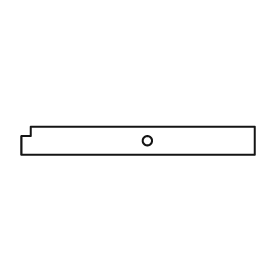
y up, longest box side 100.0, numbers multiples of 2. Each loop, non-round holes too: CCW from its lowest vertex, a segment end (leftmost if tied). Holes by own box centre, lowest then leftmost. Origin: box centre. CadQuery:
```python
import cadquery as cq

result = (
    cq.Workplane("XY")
    .moveTo(-50.0, -6.0)
    .lineTo(50.0, -6.0)
    .lineTo(50.0, 6.0)
    .lineTo(-46.0, 6.0)
    .lineTo(-46.0, 2.0)
    .lineTo(-50.0, 2.0)
    .close()
    .moveTo(4.0, 0.0)
    .circle(2.0)
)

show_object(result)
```